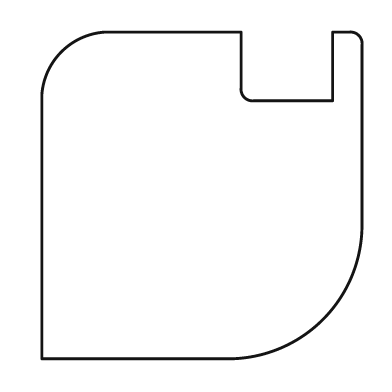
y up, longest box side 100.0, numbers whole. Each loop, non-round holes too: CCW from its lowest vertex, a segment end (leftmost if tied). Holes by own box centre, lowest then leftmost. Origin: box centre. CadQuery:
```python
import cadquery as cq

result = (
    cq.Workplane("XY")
    .moveTo(-49.0, -50.0)
    .lineTo(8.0, -50.0)
    .threePointArc((37.0, -38.0), (49.0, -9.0))
    .lineTo(49.0, 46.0)
    .threePointArc((48.0, 49.0), (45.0, 50.0))
    .lineTo(40.0, 50.0)
    .lineTo(40.0, 29.0)
    .lineTo(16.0, 29.0)
    .threePointArc((13.0, 30.0), (12.0, 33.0))
    .lineTo(12.0, 50.0)
    .lineTo(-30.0, 50.0)
    .threePointArc((-43.0, 44.0), (-49.0, 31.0))
    .close()
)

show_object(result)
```